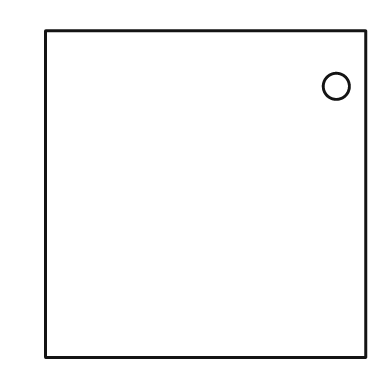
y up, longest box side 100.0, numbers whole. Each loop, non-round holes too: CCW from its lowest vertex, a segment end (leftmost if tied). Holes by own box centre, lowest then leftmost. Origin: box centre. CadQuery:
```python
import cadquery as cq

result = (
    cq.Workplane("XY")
    .moveTo(-49.0, -50.0)
    .lineTo(49.0, -50.0)
    .lineTo(49.0, 50.0)
    .lineTo(-49.0, 50.0)
    .close()
    .moveTo(40.0, 33.0)
    .circle(4.0)
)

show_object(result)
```